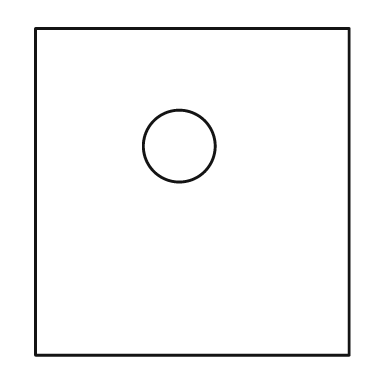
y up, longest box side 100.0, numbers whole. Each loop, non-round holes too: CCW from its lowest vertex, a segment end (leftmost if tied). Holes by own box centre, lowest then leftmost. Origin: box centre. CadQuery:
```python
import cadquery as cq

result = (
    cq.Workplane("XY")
    .moveTo(-48.0, -50.0)
    .lineTo(48.0, -50.0)
    .lineTo(48.0, 50.0)
    .lineTo(-48.0, 50.0)
    .close()
    .moveTo(-4.0, 14.0)
    .circle(11.0)
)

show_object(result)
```